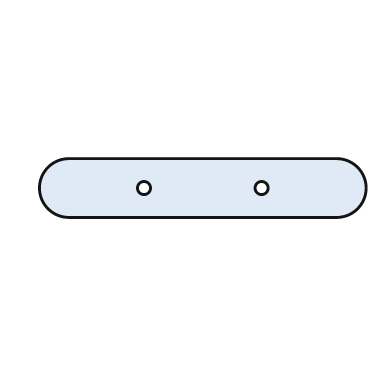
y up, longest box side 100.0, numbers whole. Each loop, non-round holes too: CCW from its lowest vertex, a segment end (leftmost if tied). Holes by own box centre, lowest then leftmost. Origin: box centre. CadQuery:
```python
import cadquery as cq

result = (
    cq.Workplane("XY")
    .moveTo(-41.0, -9.0)
    .lineTo(41.0, -9.0)
    .threePointArc((50.0, 0.0), (41.0, 9.0))
    .lineTo(-41.0, 9.0)
    .threePointArc((-50.0, 0.0), (-41.0, -9.0))
    .close()
    .moveTo(-18.0, 0.0)
    .circle(2.0)
    .moveTo(18.0, 0.0)
    .circle(2.0)
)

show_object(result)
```